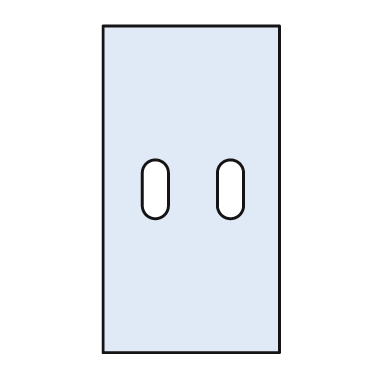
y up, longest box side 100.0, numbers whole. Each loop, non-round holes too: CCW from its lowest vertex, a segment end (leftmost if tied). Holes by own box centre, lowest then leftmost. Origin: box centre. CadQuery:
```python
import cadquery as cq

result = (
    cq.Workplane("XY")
    .moveTo(-27.0, -50.0)
    .lineTo(27.0, -50.0)
    .lineTo(27.0, 50.0)
    .lineTo(-27.0, 50.0)
    .close()
    .moveTo(-15.0, -5.0)
    .threePointArc((-11.0, -9.0), (-7.0, -5.0))
    .lineTo(-7.0, 5.0)
    .threePointArc((-11.0, 9.0), (-15.0, 5.0))
    .close()
    .moveTo(8.0, -5.0)
    .threePointArc((12.0, -9.0), (16.0, -5.0))
    .lineTo(16.0, 5.0)
    .threePointArc((12.0, 9.0), (8.0, 5.0))
    .close()
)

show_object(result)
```